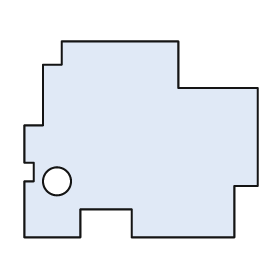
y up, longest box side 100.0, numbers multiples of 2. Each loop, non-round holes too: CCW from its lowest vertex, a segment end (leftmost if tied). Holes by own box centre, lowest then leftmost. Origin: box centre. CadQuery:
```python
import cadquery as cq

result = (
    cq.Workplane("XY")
    .moveTo(-50.0, -42.0)
    .lineTo(-26.0, -42.0)
    .lineTo(-26.0, -30.0)
    .lineTo(-4.0, -30.0)
    .lineTo(-4.0, -42.0)
    .lineTo(40.0, -42.0)
    .lineTo(40.0, -20.0)
    .lineTo(50.0, -20.0)
    .lineTo(50.0, 22.0)
    .lineTo(16.0, 22.0)
    .lineTo(16.0, 42.0)
    .lineTo(-34.0, 42.0)
    .lineTo(-34.0, 32.0)
    .lineTo(-42.0, 32.0)
    .lineTo(-42.0, 6.0)
    .lineTo(-50.0, 6.0)
    .lineTo(-50.0, -10.0)
    .lineTo(-46.0, -10.0)
    .lineTo(-46.0, -18.0)
    .lineTo(-50.0, -18.0)
    .close()
    .moveTo(-36.0, -18.0)
    .circle(6.0)
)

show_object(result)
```